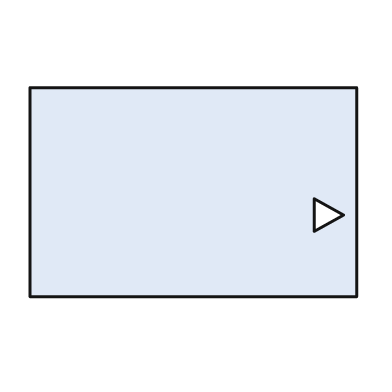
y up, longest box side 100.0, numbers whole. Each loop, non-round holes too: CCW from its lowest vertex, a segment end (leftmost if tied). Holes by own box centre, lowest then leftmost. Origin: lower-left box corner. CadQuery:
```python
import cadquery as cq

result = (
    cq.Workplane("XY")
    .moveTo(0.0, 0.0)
    .lineTo(100.0, 0.0)
    .lineTo(100.0, 64.0)
    .lineTo(0.0, 64.0)
    .close()
    .moveTo(87.0, 20.0)
    .lineTo(96.0, 25.0)
    .lineTo(87.0, 30.0)
    .close()
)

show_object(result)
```